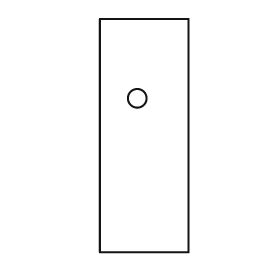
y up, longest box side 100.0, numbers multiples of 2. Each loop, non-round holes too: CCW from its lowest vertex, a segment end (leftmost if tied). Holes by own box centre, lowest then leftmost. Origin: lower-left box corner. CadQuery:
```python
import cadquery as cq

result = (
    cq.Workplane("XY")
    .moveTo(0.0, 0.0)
    .lineTo(38.0, 0.0)
    .lineTo(38.0, 100.0)
    .lineTo(0.0, 100.0)
    .close()
    .moveTo(16.0, 66.0)
    .circle(4.0)
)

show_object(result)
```